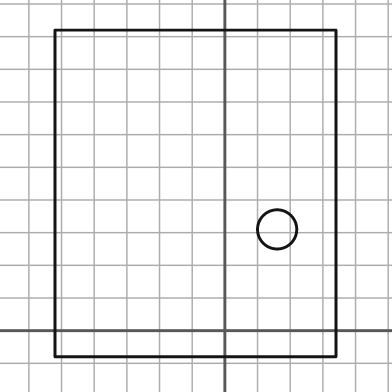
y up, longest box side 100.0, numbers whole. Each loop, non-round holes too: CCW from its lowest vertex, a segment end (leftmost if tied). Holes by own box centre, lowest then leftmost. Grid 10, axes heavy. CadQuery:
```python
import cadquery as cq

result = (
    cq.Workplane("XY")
    .moveTo(-52.0, -8.0)
    .lineTo(34.0, -8.0)
    .lineTo(34.0, 92.0)
    .lineTo(-52.0, 92.0)
    .close()
    .moveTo(16.0, 31.0)
    .circle(6.0)
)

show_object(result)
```